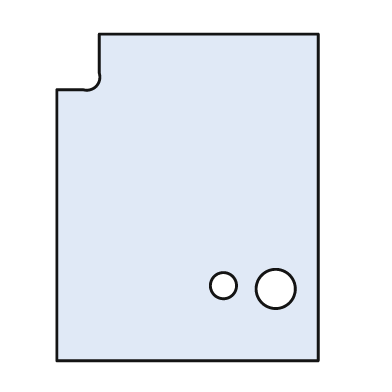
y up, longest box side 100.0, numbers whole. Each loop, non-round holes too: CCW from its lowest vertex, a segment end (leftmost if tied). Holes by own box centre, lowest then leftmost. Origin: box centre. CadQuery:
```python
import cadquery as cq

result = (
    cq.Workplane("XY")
    .moveTo(-40.0, -50.0)
    .lineTo(40.0, -50.0)
    .lineTo(40.0, 50.0)
    .lineTo(-27.0, 50.0)
    .lineTo(-27.0, 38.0)
    .threePointArc((-28.0, 34.0), (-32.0, 33.0))
    .lineTo(-40.0, 33.0)
    .close()
    .moveTo(27.0, -28.0)
    .circle(6.0)
    .moveTo(11.0, -27.0)
    .circle(4.0)
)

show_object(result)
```